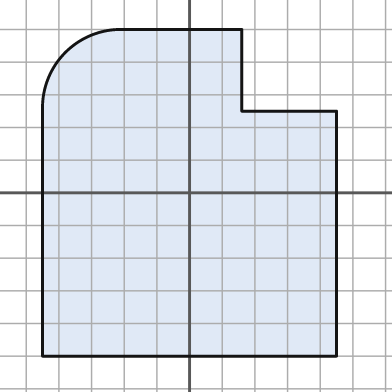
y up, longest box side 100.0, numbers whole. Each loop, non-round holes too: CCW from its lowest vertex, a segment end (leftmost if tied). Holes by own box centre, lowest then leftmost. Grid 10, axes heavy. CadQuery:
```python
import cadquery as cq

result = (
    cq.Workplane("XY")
    .moveTo(-45.0, -50.0)
    .lineTo(45.0, -50.0)
    .lineTo(45.0, 25.0)
    .lineTo(16.0, 25.0)
    .lineTo(16.0, 50.0)
    .lineTo(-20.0, 50.0)
    .threePointArc((-38.0, 43.0), (-45.0, 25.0))
    .close()
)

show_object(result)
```